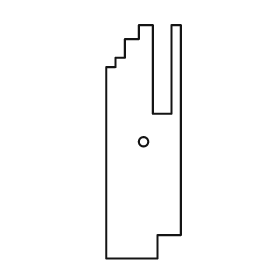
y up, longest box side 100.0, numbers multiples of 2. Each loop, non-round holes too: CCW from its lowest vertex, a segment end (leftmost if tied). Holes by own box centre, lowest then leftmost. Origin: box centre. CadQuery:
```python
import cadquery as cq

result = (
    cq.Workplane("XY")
    .moveTo(-16.0, -50.0)
    .lineTo(6.0, -50.0)
    .lineTo(6.0, -40.0)
    .lineTo(16.0, -40.0)
    .lineTo(16.0, 50.0)
    .lineTo(12.0, 50.0)
    .lineTo(12.0, 12.0)
    .lineTo(4.0, 12.0)
    .lineTo(4.0, 50.0)
    .lineTo(-2.0, 50.0)
    .lineTo(-2.0, 44.0)
    .lineTo(-8.0, 44.0)
    .lineTo(-8.0, 36.0)
    .lineTo(-12.0, 36.0)
    .lineTo(-12.0, 32.0)
    .lineTo(-16.0, 32.0)
    .close()
    .moveTo(0.0, 0.0)
    .circle(2.0)
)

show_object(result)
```